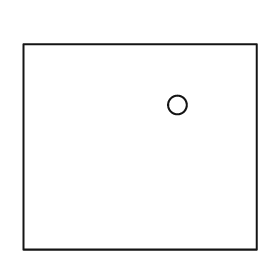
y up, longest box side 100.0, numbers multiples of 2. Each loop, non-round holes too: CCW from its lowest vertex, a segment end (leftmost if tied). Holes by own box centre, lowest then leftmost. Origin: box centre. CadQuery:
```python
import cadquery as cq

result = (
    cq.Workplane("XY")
    .moveTo(-50.0, -44.0)
    .lineTo(50.0, -44.0)
    .lineTo(50.0, 44.0)
    .lineTo(-50.0, 44.0)
    .close()
    .moveTo(16.0, 18.0)
    .circle(4.0)
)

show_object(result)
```